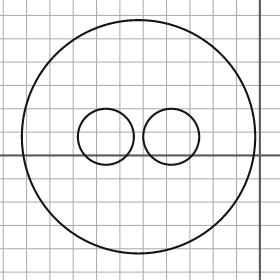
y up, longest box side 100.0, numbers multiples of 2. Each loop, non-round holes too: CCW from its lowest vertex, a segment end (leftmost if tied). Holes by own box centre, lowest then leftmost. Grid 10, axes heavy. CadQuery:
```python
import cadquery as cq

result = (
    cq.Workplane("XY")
    .moveTo(-52.0, 8.0)
    .circle(50.0)
    .moveTo(-66.0, 8.0)
    .circle(12.0)
    .moveTo(-38.0, 8.0)
    .circle(12.0)
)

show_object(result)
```